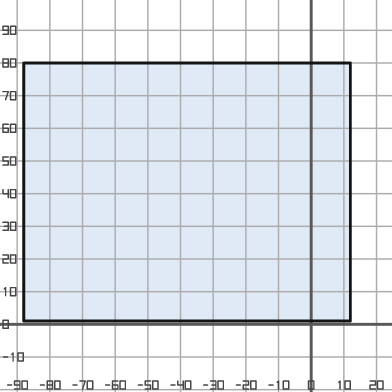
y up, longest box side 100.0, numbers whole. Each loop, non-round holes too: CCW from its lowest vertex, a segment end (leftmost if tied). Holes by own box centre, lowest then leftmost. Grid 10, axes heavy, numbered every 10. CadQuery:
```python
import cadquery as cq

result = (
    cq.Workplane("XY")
    .moveTo(-88.0, 1.0)
    .lineTo(12.0, 1.0)
    .lineTo(12.0, 80.0)
    .lineTo(-88.0, 80.0)
    .close()
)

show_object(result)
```